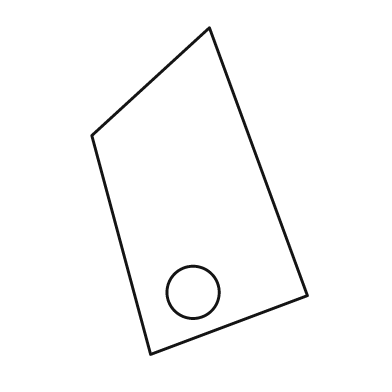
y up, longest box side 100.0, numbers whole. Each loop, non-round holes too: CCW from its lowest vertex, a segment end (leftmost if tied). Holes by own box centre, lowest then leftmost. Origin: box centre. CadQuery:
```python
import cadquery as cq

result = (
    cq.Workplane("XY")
    .moveTo(-15.0, -50.0)
    .lineTo(33.0, -32.0)
    .lineTo(3.0, 50.0)
    .lineTo(-33.0, 17.0)
    .close()
    .moveTo(-2.0, -31.0)
    .circle(8.0)
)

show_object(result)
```